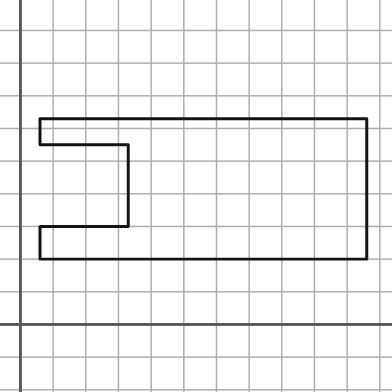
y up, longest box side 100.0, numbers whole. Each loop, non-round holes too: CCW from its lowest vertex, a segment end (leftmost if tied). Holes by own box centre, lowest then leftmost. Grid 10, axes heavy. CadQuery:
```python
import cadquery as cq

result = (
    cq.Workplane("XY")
    .moveTo(6.0, 20.0)
    .lineTo(106.0, 20.0)
    .lineTo(106.0, 63.0)
    .lineTo(6.0, 63.0)
    .lineTo(6.0, 55.0)
    .lineTo(33.0, 55.0)
    .lineTo(33.0, 30.0)
    .lineTo(6.0, 30.0)
    .close()
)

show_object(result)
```